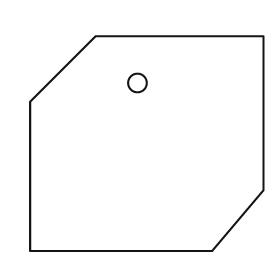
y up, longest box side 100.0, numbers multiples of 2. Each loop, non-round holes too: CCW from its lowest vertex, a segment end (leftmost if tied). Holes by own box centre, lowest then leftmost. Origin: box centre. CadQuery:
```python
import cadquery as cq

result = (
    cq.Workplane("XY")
    .moveTo(-50.0, -46.0)
    .lineTo(28.0, -46.0)
    .lineTo(50.0, -20.0)
    .lineTo(50.0, 46.0)
    .lineTo(-22.0, 46.0)
    .lineTo(-50.0, 18.0)
    .close()
    .moveTo(-4.0, 26.0)
    .circle(4.0)
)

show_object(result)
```